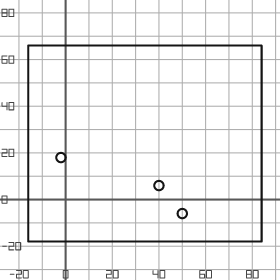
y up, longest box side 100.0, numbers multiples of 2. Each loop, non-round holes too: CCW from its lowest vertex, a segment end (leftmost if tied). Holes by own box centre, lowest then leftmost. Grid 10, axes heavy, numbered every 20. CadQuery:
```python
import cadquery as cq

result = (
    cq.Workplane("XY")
    .moveTo(-16.0, -18.0)
    .lineTo(84.0, -18.0)
    .lineTo(84.0, 66.0)
    .lineTo(-16.0, 66.0)
    .close()
    .moveTo(50.0, -6.0)
    .circle(2.0)
    .moveTo(40.0, 6.0)
    .circle(2.0)
    .moveTo(-2.0, 18.0)
    .circle(2.0)
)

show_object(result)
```